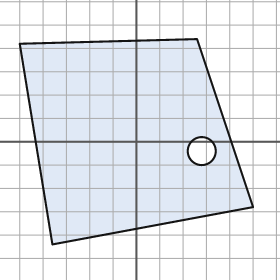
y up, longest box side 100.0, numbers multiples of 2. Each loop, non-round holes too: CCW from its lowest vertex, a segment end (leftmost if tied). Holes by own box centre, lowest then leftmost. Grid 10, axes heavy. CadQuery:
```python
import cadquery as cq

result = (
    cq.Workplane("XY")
    .moveTo(-36.0, -44.0)
    .lineTo(50.0, -28.0)
    .lineTo(26.0, 44.0)
    .lineTo(-50.0, 42.0)
    .close()
    .moveTo(28.0, -4.0)
    .circle(6.0)
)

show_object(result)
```